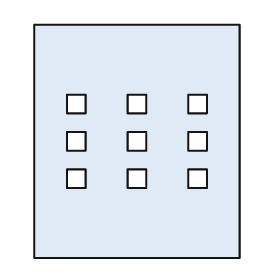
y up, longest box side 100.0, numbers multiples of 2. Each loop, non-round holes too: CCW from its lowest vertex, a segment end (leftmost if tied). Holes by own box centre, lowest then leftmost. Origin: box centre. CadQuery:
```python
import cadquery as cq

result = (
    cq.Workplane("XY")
    .moveTo(-44.0, -50.0)
    .lineTo(44.0, -50.0)
    .lineTo(44.0, 50.0)
    .lineTo(-44.0, 50.0)
    .close()
    .moveTo(-30.0, -20.0)
    .lineTo(-22.0, -20.0)
    .lineTo(-22.0, -12.0)
    .lineTo(-30.0, -12.0)
    .close()
    .moveTo(-4.0, -20.0)
    .lineTo(4.0, -20.0)
    .lineTo(4.0, -12.0)
    .lineTo(-4.0, -12.0)
    .close()
    .moveTo(22.0, -20.0)
    .lineTo(30.0, -20.0)
    .lineTo(30.0, -12.0)
    .lineTo(22.0, -12.0)
    .close()
    .moveTo(-30.0, -4.0)
    .lineTo(-22.0, -4.0)
    .lineTo(-22.0, 4.0)
    .lineTo(-30.0, 4.0)
    .close()
    .moveTo(-4.0, -4.0)
    .lineTo(4.0, -4.0)
    .lineTo(4.0, 4.0)
    .lineTo(-4.0, 4.0)
    .close()
    .moveTo(22.0, -4.0)
    .lineTo(30.0, -4.0)
    .lineTo(30.0, 4.0)
    .lineTo(22.0, 4.0)
    .close()
    .moveTo(-30.0, 12.0)
    .lineTo(-22.0, 12.0)
    .lineTo(-22.0, 20.0)
    .lineTo(-30.0, 20.0)
    .close()
    .moveTo(-4.0, 12.0)
    .lineTo(4.0, 12.0)
    .lineTo(4.0, 20.0)
    .lineTo(-4.0, 20.0)
    .close()
    .moveTo(22.0, 12.0)
    .lineTo(30.0, 12.0)
    .lineTo(30.0, 20.0)
    .lineTo(22.0, 20.0)
    .close()
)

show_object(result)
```